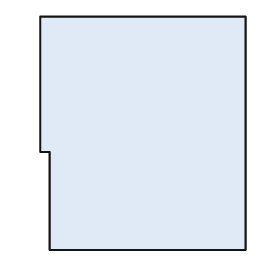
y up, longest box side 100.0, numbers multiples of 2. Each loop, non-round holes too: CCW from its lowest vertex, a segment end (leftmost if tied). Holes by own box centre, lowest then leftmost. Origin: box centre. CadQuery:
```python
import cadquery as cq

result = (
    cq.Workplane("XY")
    .moveTo(-40.0, -50.0)
    .lineTo(44.0, -50.0)
    .lineTo(44.0, 50.0)
    .lineTo(-44.0, 50.0)
    .lineTo(-44.0, -8.0)
    .lineTo(-40.0, -8.0)
    .close()
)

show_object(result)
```